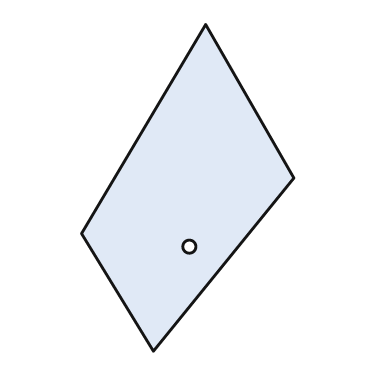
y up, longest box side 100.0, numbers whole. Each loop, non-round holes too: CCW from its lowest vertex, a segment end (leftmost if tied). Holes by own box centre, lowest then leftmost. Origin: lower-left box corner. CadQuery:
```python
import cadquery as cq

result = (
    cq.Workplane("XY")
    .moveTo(22.0, 0.0)
    .lineTo(65.0, 53.0)
    .lineTo(38.0, 100.0)
    .lineTo(0.0, 36.0)
    .close()
    .moveTo(33.0, 32.0)
    .circle(2.0)
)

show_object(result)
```